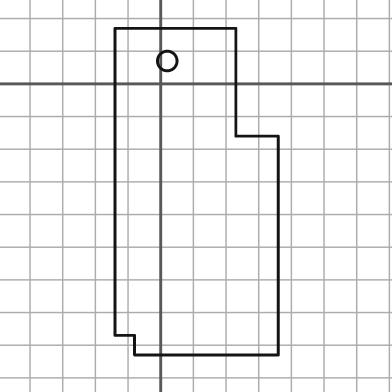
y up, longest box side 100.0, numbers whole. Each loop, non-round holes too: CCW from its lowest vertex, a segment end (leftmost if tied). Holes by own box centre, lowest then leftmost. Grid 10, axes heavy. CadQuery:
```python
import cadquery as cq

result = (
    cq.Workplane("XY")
    .moveTo(-8.0, -83.0)
    .lineTo(36.0, -83.0)
    .lineTo(36.0, -16.0)
    .lineTo(23.0, -16.0)
    .lineTo(23.0, 17.0)
    .lineTo(-14.0, 17.0)
    .lineTo(-14.0, -77.0)
    .lineTo(-8.0, -77.0)
    .close()
    .moveTo(2.0, 7.0)
    .circle(3.0)
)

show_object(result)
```